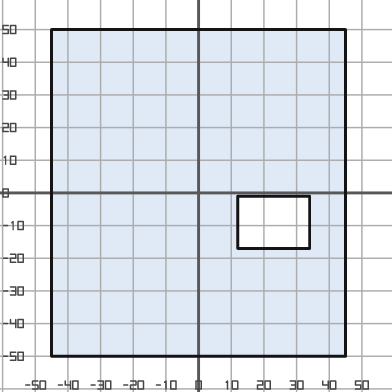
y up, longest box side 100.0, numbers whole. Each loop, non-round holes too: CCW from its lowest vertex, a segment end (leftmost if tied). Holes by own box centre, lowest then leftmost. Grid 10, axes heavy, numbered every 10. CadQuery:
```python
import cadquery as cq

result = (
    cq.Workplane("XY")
    .moveTo(-45.0, -50.0)
    .lineTo(45.0, -50.0)
    .lineTo(45.0, 50.0)
    .lineTo(-45.0, 50.0)
    .close()
    .moveTo(12.0, -17.0)
    .lineTo(34.0, -17.0)
    .lineTo(34.0, -1.0)
    .lineTo(12.0, -1.0)
    .close()
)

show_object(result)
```